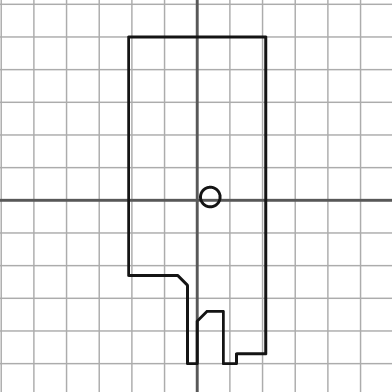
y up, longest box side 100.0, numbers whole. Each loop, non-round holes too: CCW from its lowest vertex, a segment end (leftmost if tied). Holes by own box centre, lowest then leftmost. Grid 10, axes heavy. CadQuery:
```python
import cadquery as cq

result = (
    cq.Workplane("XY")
    .moveTo(-3.0, -50.0)
    .lineTo(0.0, -50.0)
    .lineTo(0.0, -37.0)
    .lineTo(3.0, -34.0)
    .lineTo(8.0, -34.0)
    .lineTo(8.0, -50.0)
    .lineTo(12.0, -50.0)
    .lineTo(12.0, -47.0)
    .lineTo(21.0, -47.0)
    .lineTo(21.0, 50.0)
    .lineTo(-21.0, 50.0)
    .lineTo(-21.0, -23.0)
    .lineTo(-6.0, -23.0)
    .lineTo(-3.0, -26.0)
    .close()
    .moveTo(4.0, 1.0)
    .circle(3.0)
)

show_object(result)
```